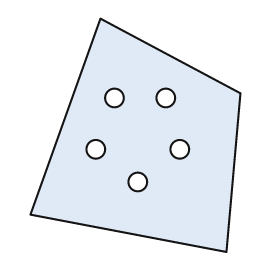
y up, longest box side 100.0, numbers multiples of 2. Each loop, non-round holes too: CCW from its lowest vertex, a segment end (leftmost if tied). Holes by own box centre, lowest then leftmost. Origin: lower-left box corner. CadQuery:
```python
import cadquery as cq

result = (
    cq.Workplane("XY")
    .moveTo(84.0, 0.0)
    .lineTo(90.0, 68.0)
    .lineTo(30.0, 100.0)
    .lineTo(0.0, 16.0)
    .close()
    .moveTo(46.0, 30.0)
    .circle(4.0)
    .moveTo(28.0, 44.0)
    .circle(4.0)
    .moveTo(64.0, 44.0)
    .circle(4.0)
    .moveTo(36.0, 66.0)
    .circle(4.0)
    .moveTo(58.0, 66.0)
    .circle(4.0)
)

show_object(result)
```